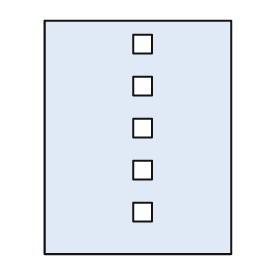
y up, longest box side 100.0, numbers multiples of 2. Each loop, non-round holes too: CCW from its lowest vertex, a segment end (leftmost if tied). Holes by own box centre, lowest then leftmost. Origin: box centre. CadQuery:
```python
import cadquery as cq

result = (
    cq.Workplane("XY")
    .moveTo(-40.0, -50.0)
    .lineTo(40.0, -50.0)
    .lineTo(40.0, 50.0)
    .lineTo(-40.0, 50.0)
    .close()
    .moveTo(-2.0, -36.0)
    .lineTo(6.0, -36.0)
    .lineTo(6.0, -28.0)
    .lineTo(-2.0, -28.0)
    .close()
    .moveTo(-2.0, -18.0)
    .lineTo(6.0, -18.0)
    .lineTo(6.0, -10.0)
    .lineTo(-2.0, -10.0)
    .close()
    .moveTo(-2.0, 0.0)
    .lineTo(6.0, 0.0)
    .lineTo(6.0, 8.0)
    .lineTo(-2.0, 8.0)
    .close()
    .moveTo(-2.0, 18.0)
    .lineTo(6.0, 18.0)
    .lineTo(6.0, 26.0)
    .lineTo(-2.0, 26.0)
    .close()
    .moveTo(-2.0, 36.0)
    .lineTo(6.0, 36.0)
    .lineTo(6.0, 44.0)
    .lineTo(-2.0, 44.0)
    .close()
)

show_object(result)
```